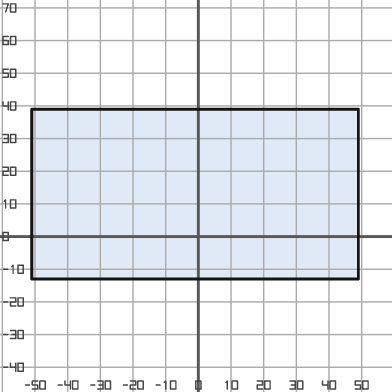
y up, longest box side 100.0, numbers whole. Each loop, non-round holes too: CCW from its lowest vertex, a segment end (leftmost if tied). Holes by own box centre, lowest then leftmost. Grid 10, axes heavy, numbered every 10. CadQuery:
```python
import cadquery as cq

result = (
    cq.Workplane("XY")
    .moveTo(-51.0, -13.0)
    .lineTo(49.0, -13.0)
    .lineTo(49.0, 39.0)
    .lineTo(-51.0, 39.0)
    .close()
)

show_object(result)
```